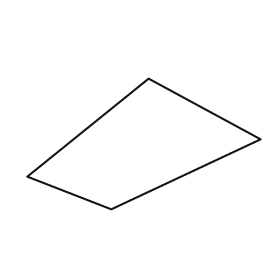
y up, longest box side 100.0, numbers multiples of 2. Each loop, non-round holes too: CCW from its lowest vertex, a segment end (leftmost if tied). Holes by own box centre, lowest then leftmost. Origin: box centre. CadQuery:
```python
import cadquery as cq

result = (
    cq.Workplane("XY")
    .moveTo(-14.0, -28.0)
    .lineTo(50.0, 2.0)
    .lineTo(2.0, 28.0)
    .lineTo(-50.0, -14.0)
    .close()
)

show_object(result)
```